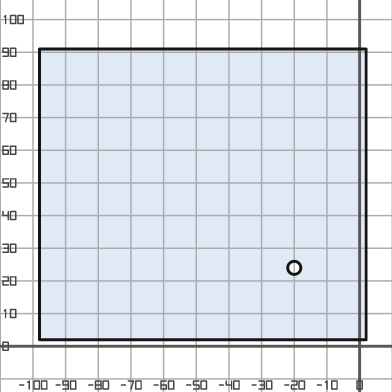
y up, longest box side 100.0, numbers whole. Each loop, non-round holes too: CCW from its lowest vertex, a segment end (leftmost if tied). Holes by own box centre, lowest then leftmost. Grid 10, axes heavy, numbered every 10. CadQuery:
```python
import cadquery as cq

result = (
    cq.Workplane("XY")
    .moveTo(-98.0, 2.0)
    .lineTo(2.0, 2.0)
    .lineTo(2.0, 91.0)
    .lineTo(-98.0, 91.0)
    .close()
    .moveTo(-20.0, 24.0)
    .circle(2.0)
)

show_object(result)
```